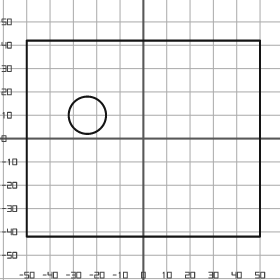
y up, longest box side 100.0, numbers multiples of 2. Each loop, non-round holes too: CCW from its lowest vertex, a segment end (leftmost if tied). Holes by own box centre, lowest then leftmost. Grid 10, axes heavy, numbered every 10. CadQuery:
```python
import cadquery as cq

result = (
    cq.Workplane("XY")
    .moveTo(-50.0, -42.0)
    .lineTo(50.0, -42.0)
    .lineTo(50.0, 42.0)
    .lineTo(-50.0, 42.0)
    .close()
    .moveTo(-24.0, 10.0)
    .circle(8.0)
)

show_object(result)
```